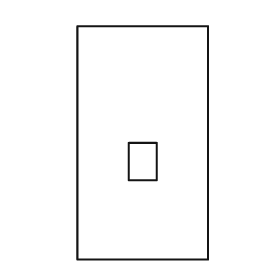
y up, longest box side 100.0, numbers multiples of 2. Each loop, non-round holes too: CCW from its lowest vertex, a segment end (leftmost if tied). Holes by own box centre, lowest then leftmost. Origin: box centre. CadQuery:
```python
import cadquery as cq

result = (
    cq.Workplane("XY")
    .moveTo(-28.0, -50.0)
    .lineTo(28.0, -50.0)
    .lineTo(28.0, 50.0)
    .lineTo(-28.0, 50.0)
    .close()
    .moveTo(-6.0, -16.0)
    .lineTo(6.0, -16.0)
    .lineTo(6.0, 0.0)
    .lineTo(-6.0, 0.0)
    .close()
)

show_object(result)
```